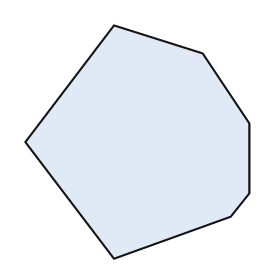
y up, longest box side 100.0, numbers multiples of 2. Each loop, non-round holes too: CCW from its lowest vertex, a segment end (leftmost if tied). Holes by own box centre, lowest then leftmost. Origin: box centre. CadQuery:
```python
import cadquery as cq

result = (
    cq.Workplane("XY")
    .moveTo(-10.0, -50.0)
    .lineTo(40.0, -32.0)
    .lineTo(48.0, -22.0)
    .lineTo(48.0, 8.0)
    .lineTo(28.0, 38.0)
    .lineTo(-10.0, 50.0)
    .lineTo(-48.0, 0.0)
    .close()
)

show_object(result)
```